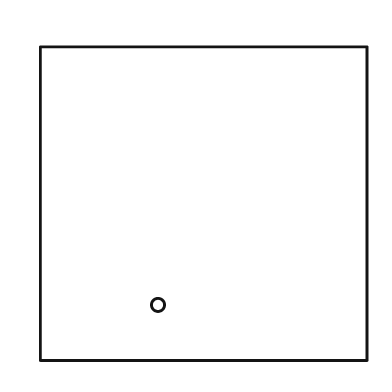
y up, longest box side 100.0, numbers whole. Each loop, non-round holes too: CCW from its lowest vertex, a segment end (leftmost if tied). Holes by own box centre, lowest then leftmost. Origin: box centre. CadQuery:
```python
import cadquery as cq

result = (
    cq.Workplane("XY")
    .moveTo(-50.0, -48.0)
    .lineTo(50.0, -48.0)
    .lineTo(50.0, 48.0)
    .lineTo(-50.0, 48.0)
    .close()
    .moveTo(-14.0, -31.0)
    .circle(2.0)
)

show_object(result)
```